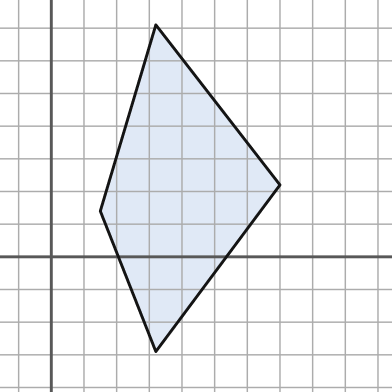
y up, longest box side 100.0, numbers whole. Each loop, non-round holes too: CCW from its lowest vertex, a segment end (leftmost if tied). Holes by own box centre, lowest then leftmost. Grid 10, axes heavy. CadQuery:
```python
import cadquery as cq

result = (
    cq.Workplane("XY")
    .moveTo(32.0, -29.0)
    .lineTo(70.0, 22.0)
    .lineTo(32.0, 71.0)
    .lineTo(15.0, 14.0)
    .close()
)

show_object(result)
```